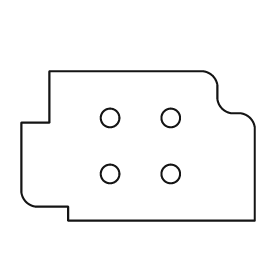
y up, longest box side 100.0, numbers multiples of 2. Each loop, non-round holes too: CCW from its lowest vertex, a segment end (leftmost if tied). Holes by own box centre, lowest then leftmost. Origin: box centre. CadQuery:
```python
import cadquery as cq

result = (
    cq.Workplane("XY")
    .moveTo(-30.0, -32.0)
    .lineTo(50.0, -32.0)
    .lineTo(50.0, 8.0)
    .threePointArc((48.0, 12.0), (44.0, 14.0))
    .lineTo(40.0, 14.0)
    .threePointArc((36.0, 16.0), (34.0, 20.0))
    .lineTo(34.0, 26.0)
    .threePointArc((32.0, 30.0), (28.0, 32.0))
    .lineTo(-38.0, 32.0)
    .lineTo(-38.0, 10.0)
    .lineTo(-50.0, 10.0)
    .lineTo(-50.0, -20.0)
    .threePointArc((-48.0, -24.0), (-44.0, -26.0))
    .lineTo(-30.0, -26.0)
    .close()
    .moveTo(-12.0, -12.0)
    .circle(4.0)
    .moveTo(14.0, -12.0)
    .circle(4.0)
    .moveTo(-12.0, 12.0)
    .circle(4.0)
    .moveTo(14.0, 12.0)
    .circle(4.0)
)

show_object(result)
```